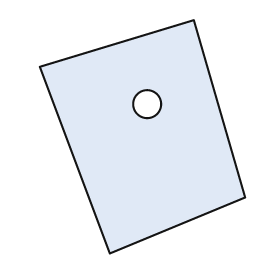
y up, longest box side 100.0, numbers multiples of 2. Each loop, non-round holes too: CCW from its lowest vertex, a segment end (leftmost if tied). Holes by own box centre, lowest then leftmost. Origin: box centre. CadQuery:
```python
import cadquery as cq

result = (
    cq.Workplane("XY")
    .moveTo(-14.0, -50.0)
    .lineTo(44.0, -26.0)
    .lineTo(22.0, 50.0)
    .lineTo(-44.0, 30.0)
    .close()
    .moveTo(2.0, 14.0)
    .circle(6.0)
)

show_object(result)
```